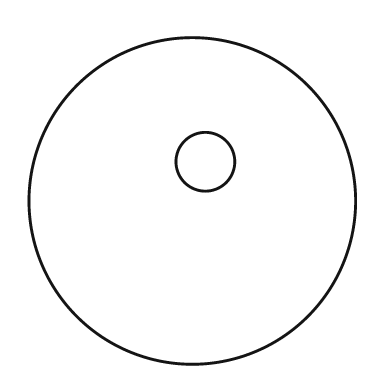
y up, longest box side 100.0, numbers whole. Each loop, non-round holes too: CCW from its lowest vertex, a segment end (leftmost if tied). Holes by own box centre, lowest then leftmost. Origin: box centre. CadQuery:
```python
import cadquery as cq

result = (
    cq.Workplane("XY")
    .moveTo(0.0, 0.0)
    .circle(50.0)
    .moveTo(4.0, 12.0)
    .circle(9.0)
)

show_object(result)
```